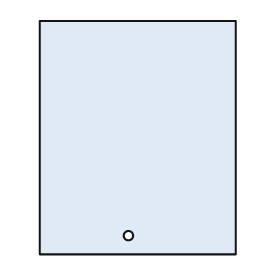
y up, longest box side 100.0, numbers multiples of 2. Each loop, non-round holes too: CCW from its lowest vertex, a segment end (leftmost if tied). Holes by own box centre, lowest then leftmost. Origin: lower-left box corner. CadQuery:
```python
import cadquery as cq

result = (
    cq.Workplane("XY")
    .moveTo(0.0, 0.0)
    .lineTo(84.0, 0.0)
    .lineTo(84.0, 100.0)
    .lineTo(0.0, 100.0)
    .close()
    .moveTo(38.0, 8.0)
    .circle(2.0)
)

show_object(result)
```